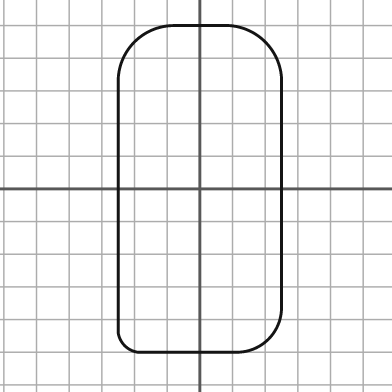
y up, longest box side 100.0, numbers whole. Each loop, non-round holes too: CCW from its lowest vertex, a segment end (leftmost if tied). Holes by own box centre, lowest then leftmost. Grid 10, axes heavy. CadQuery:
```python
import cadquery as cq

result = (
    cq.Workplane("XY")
    .moveTo(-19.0, -50.0)
    .lineTo(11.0, -50.0)
    .threePointArc((21.0, -46.0), (25.0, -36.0))
    .lineTo(25.0, 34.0)
    .threePointArc((20.0, 45.0), (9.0, 50.0))
    .lineTo(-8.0, 50.0)
    .threePointArc((-20.0, 45.0), (-25.0, 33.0))
    .lineTo(-25.0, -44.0)
    .threePointArc((-23.0, -48.0), (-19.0, -50.0))
    .close()
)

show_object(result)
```